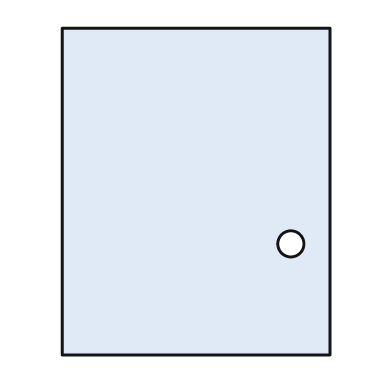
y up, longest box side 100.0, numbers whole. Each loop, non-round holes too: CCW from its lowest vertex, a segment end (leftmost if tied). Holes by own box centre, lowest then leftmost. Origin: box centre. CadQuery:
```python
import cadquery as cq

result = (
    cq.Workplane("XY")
    .moveTo(-41.0, -50.0)
    .lineTo(41.0, -50.0)
    .lineTo(41.0, 50.0)
    .lineTo(-41.0, 50.0)
    .close()
    .moveTo(29.0, -16.0)
    .circle(4.0)
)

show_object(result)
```